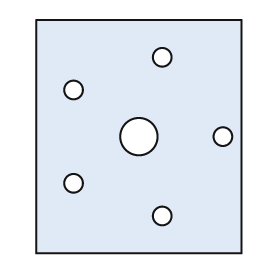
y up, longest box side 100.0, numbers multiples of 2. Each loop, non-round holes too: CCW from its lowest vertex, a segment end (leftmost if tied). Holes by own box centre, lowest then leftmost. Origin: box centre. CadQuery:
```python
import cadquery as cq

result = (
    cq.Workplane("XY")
    .moveTo(-44.0, -50.0)
    .lineTo(44.0, -50.0)
    .lineTo(44.0, 50.0)
    .lineTo(-44.0, 50.0)
    .close()
    .moveTo(10.0, -34.0)
    .circle(4.0)
    .moveTo(-28.0, -20.0)
    .circle(4.0)
    .moveTo(0.0, 0.0)
    .circle(8.0)
    .moveTo(36.0, 0.0)
    .circle(4.0)
    .moveTo(-28.0, 20.0)
    .circle(4.0)
    .moveTo(10.0, 34.0)
    .circle(4.0)
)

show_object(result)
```